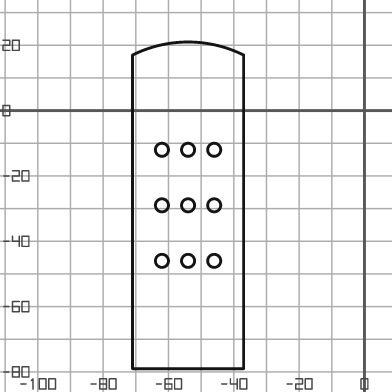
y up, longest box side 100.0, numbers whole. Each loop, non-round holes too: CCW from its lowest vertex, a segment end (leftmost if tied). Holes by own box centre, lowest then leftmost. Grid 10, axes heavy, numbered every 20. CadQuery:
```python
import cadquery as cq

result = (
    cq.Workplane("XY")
    .moveTo(-71.0, -79.0)
    .lineTo(-37.0, -79.0)
    .lineTo(-37.0, 17.0)
    .threePointArc((-54.0, 21.0), (-71.0, 17.0))
    .close()
    .moveTo(-62.0, -46.0)
    .circle(2.0)
    .moveTo(-54.0, -46.0)
    .circle(2.0)
    .moveTo(-46.0, -46.0)
    .circle(2.0)
    .moveTo(-62.0, -29.0)
    .circle(2.0)
    .moveTo(-54.0, -29.0)
    .circle(2.0)
    .moveTo(-46.0, -29.0)
    .circle(2.0)
    .moveTo(-62.0, -12.0)
    .circle(2.0)
    .moveTo(-54.0, -12.0)
    .circle(2.0)
    .moveTo(-46.0, -12.0)
    .circle(2.0)
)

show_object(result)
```